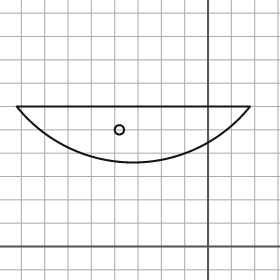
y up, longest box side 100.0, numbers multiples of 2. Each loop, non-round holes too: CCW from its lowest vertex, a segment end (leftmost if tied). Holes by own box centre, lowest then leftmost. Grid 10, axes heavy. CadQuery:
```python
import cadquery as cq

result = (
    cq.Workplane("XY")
    .moveTo(-82.0, 60.0)
    .threePointArc((-32.0, 36.0), (18.0, 60.0))
    .close()
    .moveTo(-38.0, 50.0)
    .circle(2.0)
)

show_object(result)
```